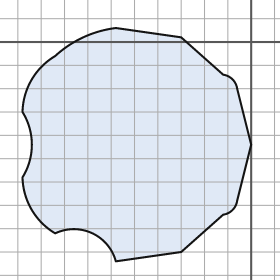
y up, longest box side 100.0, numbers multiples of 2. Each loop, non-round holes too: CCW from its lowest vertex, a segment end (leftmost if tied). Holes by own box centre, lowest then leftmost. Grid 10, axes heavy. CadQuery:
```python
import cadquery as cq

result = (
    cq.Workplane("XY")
    .moveTo(-58.0, -94.0)
    .lineTo(-30.0, -90.0)
    .lineTo(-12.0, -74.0)
    .threePointArc((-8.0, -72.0), (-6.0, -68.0))
    .lineTo(0.0, -44.0)
    .lineTo(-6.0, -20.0)
    .threePointArc((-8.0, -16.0), (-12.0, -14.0))
    .lineTo(-30.0, 2.0)
    .lineTo(-58.0, 6.0)
    .threePointArc((-72.0, 2.0), (-84.0, -6.0))
    .threePointArc((-94.0, -16.0), (-98.0, -30.0))
    .threePointArc((-94.0, -44.0), (-98.0, -58.0))
    .threePointArc((-94.0, -72.0), (-84.0, -82.0))
    .threePointArc((-68.0, -82.0), (-58.0, -94.0))
    .close()
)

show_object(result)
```